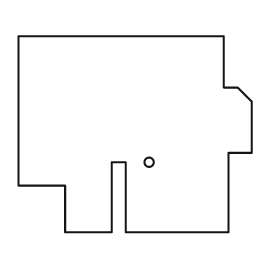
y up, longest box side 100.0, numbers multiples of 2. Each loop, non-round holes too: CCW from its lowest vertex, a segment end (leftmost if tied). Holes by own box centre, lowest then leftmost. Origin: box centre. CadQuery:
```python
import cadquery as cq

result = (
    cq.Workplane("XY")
    .moveTo(-30.0, -42.0)
    .lineTo(-10.0, -42.0)
    .lineTo(-10.0, -12.0)
    .lineTo(-4.0, -12.0)
    .lineTo(-4.0, -42.0)
    .lineTo(40.0, -42.0)
    .lineTo(40.0, -8.0)
    .lineTo(50.0, -8.0)
    .lineTo(50.0, 14.0)
    .lineTo(44.0, 20.0)
    .lineTo(38.0, 20.0)
    .lineTo(38.0, 42.0)
    .lineTo(-50.0, 42.0)
    .lineTo(-50.0, -22.0)
    .lineTo(-30.0, -22.0)
    .close()
    .moveTo(6.0, -12.0)
    .circle(2.0)
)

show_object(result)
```